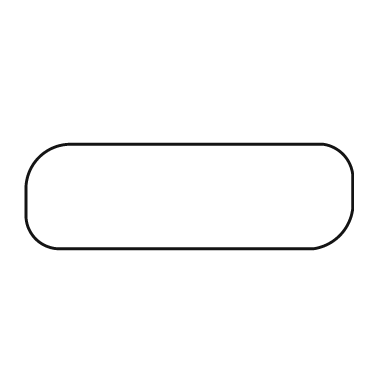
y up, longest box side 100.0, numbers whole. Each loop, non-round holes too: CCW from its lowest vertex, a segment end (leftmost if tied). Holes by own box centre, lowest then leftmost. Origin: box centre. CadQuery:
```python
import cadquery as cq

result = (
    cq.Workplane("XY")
    .moveTo(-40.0, -16.0)
    .lineTo(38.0, -16.0)
    .threePointArc((46.0, -12.0), (50.0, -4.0))
    .lineTo(50.0, 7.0)
    .threePointArc((47.0, 13.0), (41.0, 16.0))
    .lineTo(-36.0, 16.0)
    .threePointArc((-46.0, 12.0), (-50.0, 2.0))
    .lineTo(-50.0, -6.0)
    .threePointArc((-47.0, -13.0), (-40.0, -16.0))
    .close()
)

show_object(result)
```